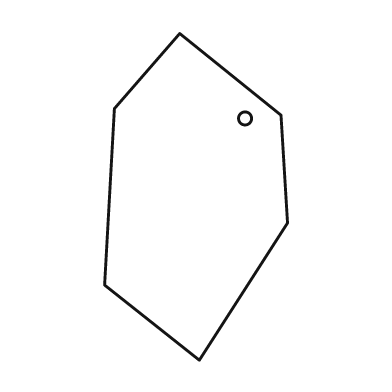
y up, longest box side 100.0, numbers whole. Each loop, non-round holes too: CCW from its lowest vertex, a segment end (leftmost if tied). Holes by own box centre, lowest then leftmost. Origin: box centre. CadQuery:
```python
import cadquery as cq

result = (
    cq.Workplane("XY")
    .moveTo(1.0, -50.0)
    .lineTo(28.0, -8.0)
    .lineTo(26.0, 25.0)
    .lineTo(-5.0, 50.0)
    .lineTo(-25.0, 27.0)
    .lineTo(-28.0, -27.0)
    .close()
    .moveTo(15.0, 24.0)
    .circle(2.0)
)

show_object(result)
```